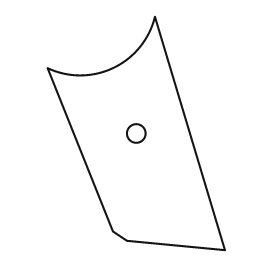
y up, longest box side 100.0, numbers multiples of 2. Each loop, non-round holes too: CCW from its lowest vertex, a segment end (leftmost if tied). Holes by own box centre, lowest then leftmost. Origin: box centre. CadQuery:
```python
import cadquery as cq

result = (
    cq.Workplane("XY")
    .moveTo(38.0, -50.0)
    .lineTo(8.0, 50.0)
    .threePointArc((-10.0, 28.0), (-38.0, 28.0))
    .lineTo(-10.0, -42.0)
    .lineTo(-4.0, -46.0)
    .close()
    .moveTo(0.0, 0.0)
    .circle(4.0)
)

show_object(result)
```